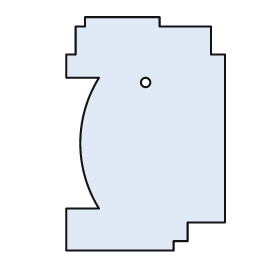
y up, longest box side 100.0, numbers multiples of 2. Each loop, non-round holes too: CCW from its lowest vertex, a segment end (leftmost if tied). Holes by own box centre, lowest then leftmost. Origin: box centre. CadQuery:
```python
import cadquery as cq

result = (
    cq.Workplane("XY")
    .moveTo(-34.0, -50.0)
    .lineTo(12.0, -50.0)
    .lineTo(12.0, -46.0)
    .lineTo(18.0, -46.0)
    .lineTo(18.0, -38.0)
    .lineTo(34.0, -38.0)
    .lineTo(34.0, 34.0)
    .lineTo(28.0, 34.0)
    .lineTo(28.0, 46.0)
    .lineTo(6.0, 46.0)
    .lineTo(6.0, 50.0)
    .lineTo(-26.0, 50.0)
    .lineTo(-26.0, 46.0)
    .lineTo(-30.0, 46.0)
    .lineTo(-30.0, 34.0)
    .lineTo(-34.0, 34.0)
    .lineTo(-34.0, 24.0)
    .lineTo(-20.0, 24.0)
    .threePointArc((-28.0, -4.0), (-20.0, -32.0))
    .lineTo(-34.0, -32.0)
    .close()
    .moveTo(0.0, 22.0)
    .circle(2.0)
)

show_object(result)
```